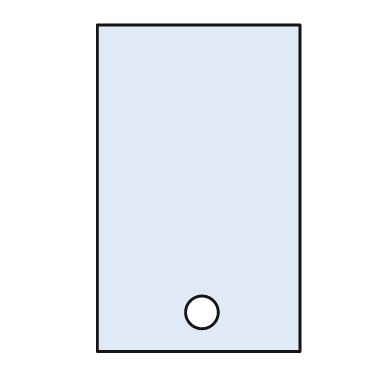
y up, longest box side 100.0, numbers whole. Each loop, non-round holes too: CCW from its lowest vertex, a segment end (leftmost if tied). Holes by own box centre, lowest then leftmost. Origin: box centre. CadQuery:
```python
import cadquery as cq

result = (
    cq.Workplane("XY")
    .moveTo(-31.0, -50.0)
    .lineTo(31.0, -50.0)
    .lineTo(31.0, 50.0)
    .lineTo(-31.0, 50.0)
    .close()
    .moveTo(1.0, -38.0)
    .circle(5.0)
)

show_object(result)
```